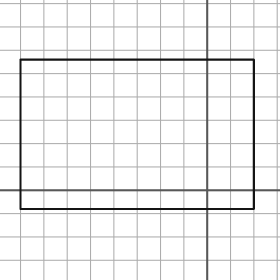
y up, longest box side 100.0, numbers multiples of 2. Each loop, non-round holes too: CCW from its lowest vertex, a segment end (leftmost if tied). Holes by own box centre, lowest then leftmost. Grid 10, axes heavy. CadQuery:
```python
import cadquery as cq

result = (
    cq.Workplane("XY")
    .moveTo(-80.0, -8.0)
    .lineTo(20.0, -8.0)
    .lineTo(20.0, 56.0)
    .lineTo(-80.0, 56.0)
    .close()
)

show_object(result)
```